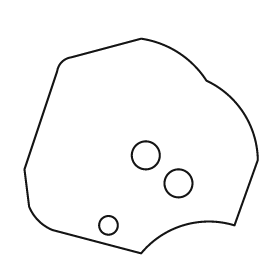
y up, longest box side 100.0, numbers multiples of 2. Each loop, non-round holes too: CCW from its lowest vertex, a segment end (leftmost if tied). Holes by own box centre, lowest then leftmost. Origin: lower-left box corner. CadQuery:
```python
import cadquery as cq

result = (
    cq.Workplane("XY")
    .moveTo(50.0, 0.0)
    .threePointArc((68.0, 12.0), (90.0, 12.0))
    .lineTo(100.0, 40.0)
    .threePointArc((94.0, 60.0), (78.0, 74.0))
    .threePointArc((66.0, 86.0), (50.0, 92.0))
    .lineTo(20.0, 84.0)
    .threePointArc((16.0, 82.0), (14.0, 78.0))
    .lineTo(0.0, 36.0)
    .lineTo(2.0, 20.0)
    .threePointArc((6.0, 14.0), (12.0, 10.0))
    .close()
    .moveTo(36.0, 12.0)
    .circle(4.0)
    .moveTo(66.0, 30.0)
    .circle(6.0)
    .moveTo(52.0, 42.0)
    .circle(6.0)
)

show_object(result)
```